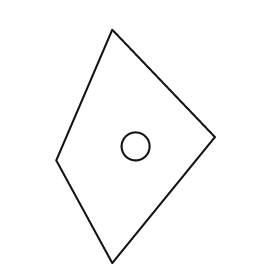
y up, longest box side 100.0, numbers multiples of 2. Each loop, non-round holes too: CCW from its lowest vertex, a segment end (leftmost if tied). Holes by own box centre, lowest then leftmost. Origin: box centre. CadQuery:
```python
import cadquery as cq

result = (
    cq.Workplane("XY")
    .moveTo(-10.0, -50.0)
    .lineTo(34.0, 4.0)
    .lineTo(-10.0, 50.0)
    .lineTo(-34.0, -6.0)
    .close()
    .moveTo(0.0, 0.0)
    .circle(6.0)
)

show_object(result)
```